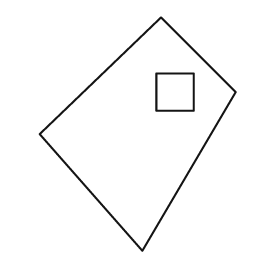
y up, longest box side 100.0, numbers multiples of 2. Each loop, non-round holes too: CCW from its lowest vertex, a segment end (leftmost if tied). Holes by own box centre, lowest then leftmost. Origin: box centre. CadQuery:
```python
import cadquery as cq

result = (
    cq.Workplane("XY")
    .moveTo(2.0, -50.0)
    .lineTo(42.0, 18.0)
    .lineTo(10.0, 50.0)
    .lineTo(-42.0, 0.0)
    .close()
    .moveTo(8.0, 10.0)
    .lineTo(24.0, 10.0)
    .lineTo(24.0, 26.0)
    .lineTo(8.0, 26.0)
    .close()
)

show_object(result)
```